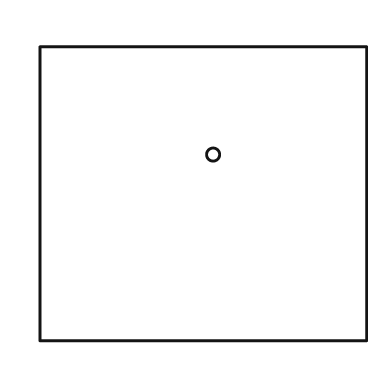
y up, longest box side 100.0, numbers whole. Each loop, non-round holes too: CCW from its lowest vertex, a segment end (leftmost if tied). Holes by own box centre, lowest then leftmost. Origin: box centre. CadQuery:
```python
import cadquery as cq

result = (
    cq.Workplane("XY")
    .moveTo(-50.0, -45.0)
    .lineTo(50.0, -45.0)
    .lineTo(50.0, 45.0)
    .lineTo(-50.0, 45.0)
    .close()
    .moveTo(3.0, 12.0)
    .circle(2.0)
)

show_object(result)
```